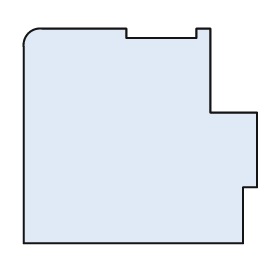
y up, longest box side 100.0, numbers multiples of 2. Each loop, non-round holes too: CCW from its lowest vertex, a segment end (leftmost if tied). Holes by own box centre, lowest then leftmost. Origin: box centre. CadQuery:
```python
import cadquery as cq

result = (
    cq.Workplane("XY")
    .moveTo(-50.0, -46.0)
    .lineTo(44.0, -46.0)
    .lineTo(44.0, -22.0)
    .lineTo(50.0, -22.0)
    .lineTo(50.0, 10.0)
    .lineTo(30.0, 10.0)
    .lineTo(30.0, 46.0)
    .lineTo(24.0, 46.0)
    .lineTo(24.0, 42.0)
    .lineTo(-6.0, 42.0)
    .lineTo(-6.0, 46.0)
    .lineTo(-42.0, 46.0)
    .threePointArc((-48.0, 44.0), (-50.0, 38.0))
    .close()
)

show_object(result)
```